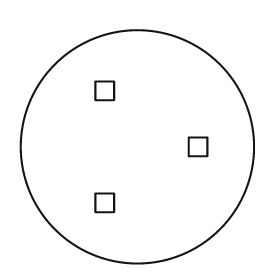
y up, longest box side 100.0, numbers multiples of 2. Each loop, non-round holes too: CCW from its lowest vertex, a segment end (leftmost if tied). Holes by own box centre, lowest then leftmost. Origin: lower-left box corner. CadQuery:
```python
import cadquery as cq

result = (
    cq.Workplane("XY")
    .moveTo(50.0, 50.0)
    .circle(50.0)
    .moveTo(32.0, 22.0)
    .lineTo(40.0, 22.0)
    .lineTo(40.0, 30.0)
    .lineTo(32.0, 30.0)
    .close()
    .moveTo(72.0, 46.0)
    .lineTo(80.0, 46.0)
    .lineTo(80.0, 54.0)
    .lineTo(72.0, 54.0)
    .close()
    .moveTo(32.0, 70.0)
    .lineTo(40.0, 70.0)
    .lineTo(40.0, 78.0)
    .lineTo(32.0, 78.0)
    .close()
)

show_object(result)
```